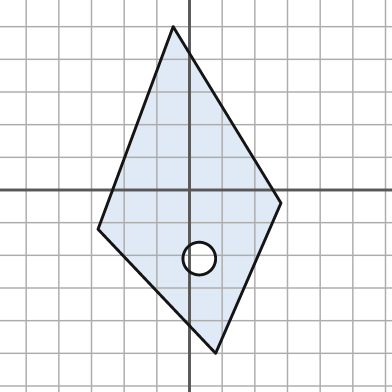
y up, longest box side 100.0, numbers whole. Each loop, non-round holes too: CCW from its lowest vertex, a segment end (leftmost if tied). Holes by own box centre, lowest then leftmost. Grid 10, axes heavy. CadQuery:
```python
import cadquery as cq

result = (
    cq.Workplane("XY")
    .moveTo(8.0, -50.0)
    .lineTo(28.0, -4.0)
    .lineTo(-5.0, 50.0)
    .lineTo(-28.0, -12.0)
    .close()
    .moveTo(3.0, -21.0)
    .circle(5.0)
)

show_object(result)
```